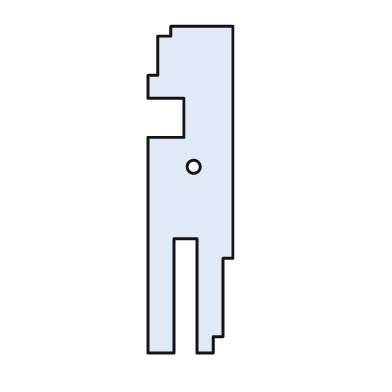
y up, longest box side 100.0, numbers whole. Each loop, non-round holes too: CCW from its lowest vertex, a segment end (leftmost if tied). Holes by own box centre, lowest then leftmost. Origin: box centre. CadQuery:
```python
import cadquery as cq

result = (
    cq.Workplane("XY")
    .moveTo(-13.0, -50.0)
    .lineTo(-5.0, -50.0)
    .lineTo(-5.0, -15.0)
    .lineTo(2.0, -15.0)
    .lineTo(2.0, -50.0)
    .lineTo(7.0, -50.0)
    .lineTo(7.0, -45.0)
    .lineTo(10.0, -45.0)
    .lineTo(10.0, -21.0)
    .lineTo(13.0, -21.0)
    .lineTo(13.0, 50.0)
    .lineTo(-6.0, 50.0)
    .lineTo(-6.0, 47.0)
    .lineTo(-10.0, 47.0)
    .lineTo(-10.0, 35.0)
    .lineTo(-13.0, 35.0)
    .lineTo(-13.0, 28.0)
    .lineTo(-2.0, 28.0)
    .lineTo(-2.0, 16.0)
    .lineTo(-13.0, 16.0)
    .close()
    .moveTo(1.0, 7.0)
    .circle(2.0)
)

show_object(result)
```